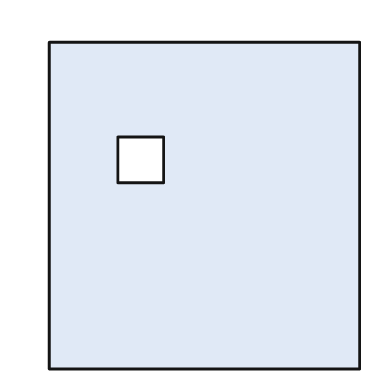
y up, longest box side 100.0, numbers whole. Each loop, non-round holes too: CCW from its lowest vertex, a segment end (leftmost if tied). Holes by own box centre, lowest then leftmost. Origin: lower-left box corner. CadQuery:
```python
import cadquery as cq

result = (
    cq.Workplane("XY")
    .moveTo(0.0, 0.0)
    .lineTo(95.0, 0.0)
    .lineTo(95.0, 100.0)
    .lineTo(0.0, 100.0)
    .close()
    .moveTo(21.0, 57.0)
    .lineTo(35.0, 57.0)
    .lineTo(35.0, 71.0)
    .lineTo(21.0, 71.0)
    .close()
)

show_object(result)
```